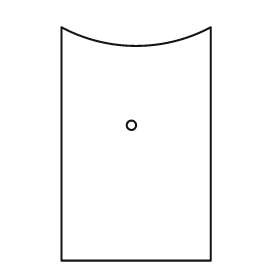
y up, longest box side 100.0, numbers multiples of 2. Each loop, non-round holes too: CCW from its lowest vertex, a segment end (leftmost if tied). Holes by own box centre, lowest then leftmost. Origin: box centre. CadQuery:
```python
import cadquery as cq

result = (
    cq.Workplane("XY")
    .moveTo(-32.0, -50.0)
    .lineTo(32.0, -50.0)
    .lineTo(32.0, 50.0)
    .threePointArc((0.0, 42.0), (-32.0, 50.0))
    .close()
    .moveTo(-2.0, 8.0)
    .circle(2.0)
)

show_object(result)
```